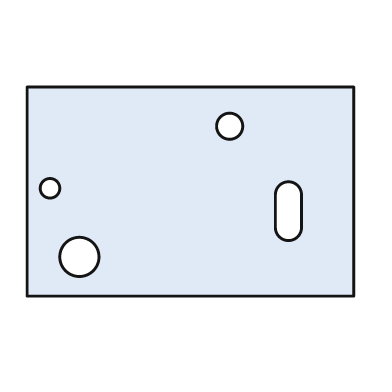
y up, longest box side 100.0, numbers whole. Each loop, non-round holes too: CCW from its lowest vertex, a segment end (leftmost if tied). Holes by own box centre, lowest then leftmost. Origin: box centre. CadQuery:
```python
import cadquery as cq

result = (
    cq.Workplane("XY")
    .moveTo(-50.0, -32.0)
    .lineTo(50.0, -32.0)
    .lineTo(50.0, 32.0)
    .lineTo(-50.0, 32.0)
    .close()
    .moveTo(-34.0, -20.0)
    .circle(6.0)
    .moveTo(26.0, -11.0)
    .threePointArc((30.0, -15.0), (34.0, -11.0))
    .lineTo(34.0, -1.0)
    .threePointArc((30.0, 3.0), (26.0, -1.0))
    .close()
    .moveTo(-43.0, 1.0)
    .circle(3.0)
    .moveTo(12.0, 20.0)
    .circle(4.0)
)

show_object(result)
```